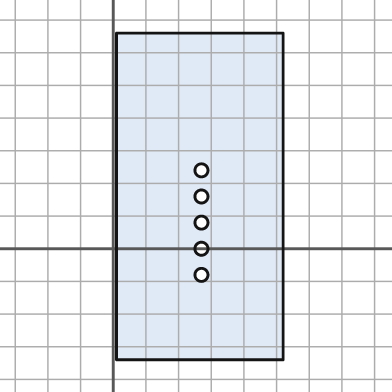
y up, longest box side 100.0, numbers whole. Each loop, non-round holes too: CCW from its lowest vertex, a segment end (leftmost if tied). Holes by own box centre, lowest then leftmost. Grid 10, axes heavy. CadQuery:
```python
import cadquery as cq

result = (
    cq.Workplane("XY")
    .moveTo(1.0, -34.0)
    .lineTo(52.0, -34.0)
    .lineTo(52.0, 66.0)
    .lineTo(1.0, 66.0)
    .close()
    .moveTo(27.0, -8.0)
    .circle(2.0)
    .moveTo(27.0, 0.0)
    .circle(2.0)
    .moveTo(27.0, 8.0)
    .circle(2.0)
    .moveTo(27.0, 16.0)
    .circle(2.0)
    .moveTo(27.0, 24.0)
    .circle(2.0)
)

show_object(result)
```